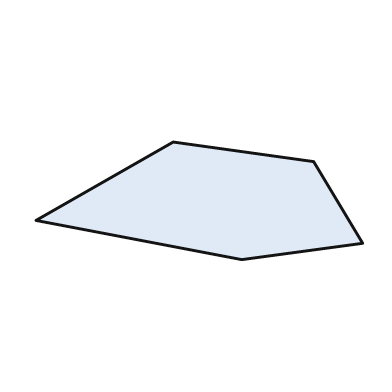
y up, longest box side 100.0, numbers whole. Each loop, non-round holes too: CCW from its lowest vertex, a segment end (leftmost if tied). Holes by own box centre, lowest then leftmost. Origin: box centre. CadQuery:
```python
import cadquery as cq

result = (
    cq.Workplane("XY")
    .moveTo(13.0, -18.0)
    .lineTo(50.0, -13.0)
    .lineTo(35.0, 12.0)
    .lineTo(-8.0, 18.0)
    .lineTo(-50.0, -6.0)
    .close()
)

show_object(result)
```